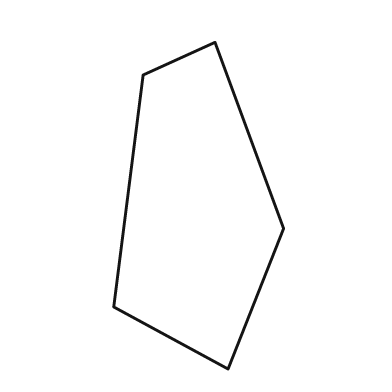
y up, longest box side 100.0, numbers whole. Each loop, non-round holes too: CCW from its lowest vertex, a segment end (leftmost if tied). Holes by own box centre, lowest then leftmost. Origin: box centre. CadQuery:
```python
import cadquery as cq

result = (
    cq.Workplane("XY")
    .moveTo(9.0, -50.0)
    .lineTo(26.0, -7.0)
    .lineTo(5.0, 50.0)
    .lineTo(-17.0, 40.0)
    .lineTo(-26.0, -31.0)
    .close()
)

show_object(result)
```